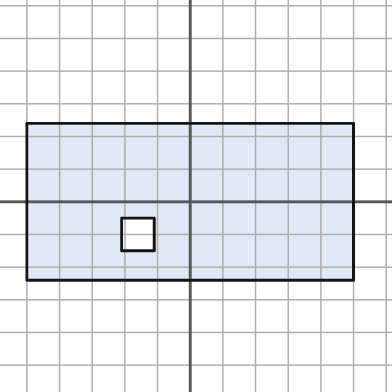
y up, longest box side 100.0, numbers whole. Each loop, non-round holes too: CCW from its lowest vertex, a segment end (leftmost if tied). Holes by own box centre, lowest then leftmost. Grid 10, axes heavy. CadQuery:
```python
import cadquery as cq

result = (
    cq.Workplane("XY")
    .moveTo(-50.0, -24.0)
    .lineTo(50.0, -24.0)
    .lineTo(50.0, 24.0)
    .lineTo(-50.0, 24.0)
    .close()
    .moveTo(-21.0, -15.0)
    .lineTo(-11.0, -15.0)
    .lineTo(-11.0, -5.0)
    .lineTo(-21.0, -5.0)
    .close()
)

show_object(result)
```